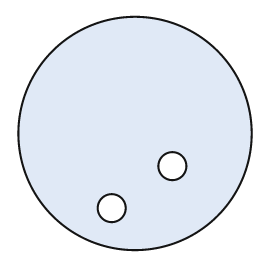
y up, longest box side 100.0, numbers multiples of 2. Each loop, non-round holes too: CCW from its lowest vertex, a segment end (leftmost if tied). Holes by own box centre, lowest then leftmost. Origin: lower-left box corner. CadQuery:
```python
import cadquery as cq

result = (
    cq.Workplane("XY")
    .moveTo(50.0, 50.0)
    .circle(50.0)
    .moveTo(40.0, 18.0)
    .circle(6.0)
    .moveTo(66.0, 36.0)
    .circle(6.0)
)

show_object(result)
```